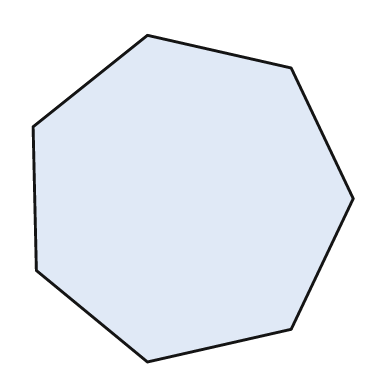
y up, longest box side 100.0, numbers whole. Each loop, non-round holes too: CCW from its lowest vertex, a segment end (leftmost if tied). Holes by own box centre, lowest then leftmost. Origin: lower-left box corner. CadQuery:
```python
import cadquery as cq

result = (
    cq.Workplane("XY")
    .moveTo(35.0, 0.0)
    .lineTo(79.0, 10.0)
    .lineTo(98.0, 50.0)
    .lineTo(79.0, 90.0)
    .lineTo(35.0, 100.0)
    .lineTo(0.0, 72.0)
    .lineTo(1.0, 28.0)
    .close()
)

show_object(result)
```